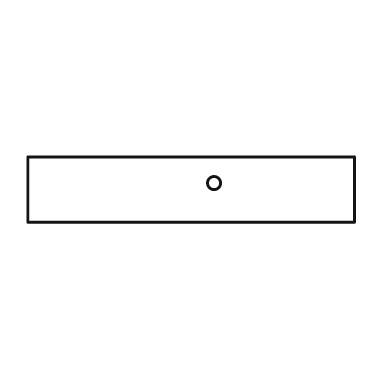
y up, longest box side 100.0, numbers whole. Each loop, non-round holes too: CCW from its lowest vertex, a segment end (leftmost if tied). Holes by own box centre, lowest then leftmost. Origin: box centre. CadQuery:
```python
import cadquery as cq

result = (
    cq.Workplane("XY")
    .moveTo(-50.0, -10.0)
    .lineTo(50.0, -10.0)
    .lineTo(50.0, 10.0)
    .lineTo(-50.0, 10.0)
    .close()
    .moveTo(7.0, 2.0)
    .circle(2.0)
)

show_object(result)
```